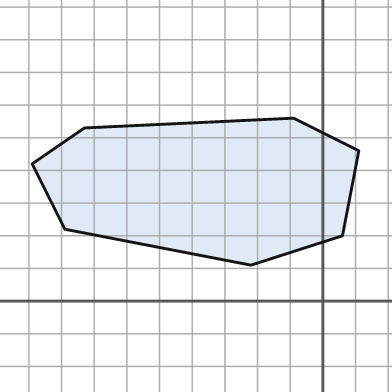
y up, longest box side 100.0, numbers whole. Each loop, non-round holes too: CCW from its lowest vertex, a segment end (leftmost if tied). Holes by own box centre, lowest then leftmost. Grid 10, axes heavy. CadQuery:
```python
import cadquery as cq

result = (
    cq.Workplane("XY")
    .moveTo(-22.0, 11.0)
    .lineTo(6.0, 20.0)
    .lineTo(11.0, 46.0)
    .lineTo(-9.0, 56.0)
    .lineTo(-73.0, 53.0)
    .lineTo(-89.0, 42.0)
    .lineTo(-79.0, 22.0)
    .close()
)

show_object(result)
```